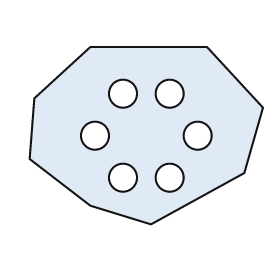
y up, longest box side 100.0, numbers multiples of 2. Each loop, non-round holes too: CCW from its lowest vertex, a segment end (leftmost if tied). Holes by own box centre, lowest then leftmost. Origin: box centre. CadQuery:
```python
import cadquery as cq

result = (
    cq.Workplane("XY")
    .moveTo(2.0, -38.0)
    .lineTo(42.0, -16.0)
    .lineTo(50.0, 12.0)
    .lineTo(26.0, 38.0)
    .lineTo(-24.0, 38.0)
    .lineTo(-48.0, 16.0)
    .lineTo(-50.0, -10.0)
    .lineTo(-24.0, -30.0)
    .close()
    .moveTo(-10.0, -18.0)
    .circle(6.0)
    .moveTo(10.0, -18.0)
    .circle(6.0)
    .moveTo(-22.0, 0.0)
    .circle(6.0)
    .moveTo(22.0, 0.0)
    .circle(6.0)
    .moveTo(-10.0, 18.0)
    .circle(6.0)
    .moveTo(10.0, 18.0)
    .circle(6.0)
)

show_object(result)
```